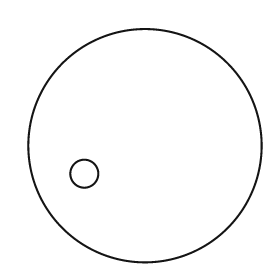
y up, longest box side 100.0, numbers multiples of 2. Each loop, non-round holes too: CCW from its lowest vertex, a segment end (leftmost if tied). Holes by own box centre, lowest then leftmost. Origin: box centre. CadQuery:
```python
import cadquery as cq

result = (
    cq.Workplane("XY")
    .moveTo(0.0, 0.0)
    .circle(50.0)
    .moveTo(-26.0, -12.0)
    .circle(6.0)
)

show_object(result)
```